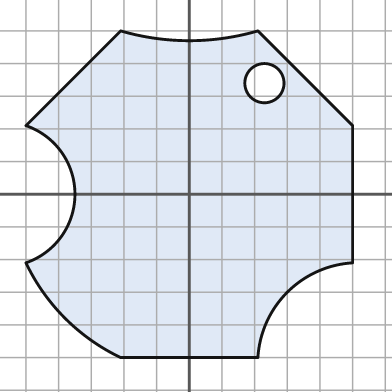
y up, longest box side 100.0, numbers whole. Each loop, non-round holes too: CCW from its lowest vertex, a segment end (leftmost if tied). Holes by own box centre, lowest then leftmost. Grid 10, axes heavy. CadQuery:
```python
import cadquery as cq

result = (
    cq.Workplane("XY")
    .moveTo(-21.0, -50.0)
    .lineTo(21.0, -50.0)
    .threePointArc((30.0, -30.0), (50.0, -21.0))
    .lineTo(50.0, 21.0)
    .lineTo(21.0, 50.0)
    .threePointArc((0.0, 47.0), (-21.0, 50.0))
    .lineTo(-50.0, 21.0)
    .threePointArc((-35.0, 0.0), (-50.0, -21.0))
    .threePointArc((-38.0, -38.0), (-21.0, -50.0))
    .close()
    .moveTo(23.0, 34.0)
    .circle(6.0)
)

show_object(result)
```